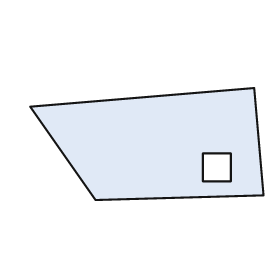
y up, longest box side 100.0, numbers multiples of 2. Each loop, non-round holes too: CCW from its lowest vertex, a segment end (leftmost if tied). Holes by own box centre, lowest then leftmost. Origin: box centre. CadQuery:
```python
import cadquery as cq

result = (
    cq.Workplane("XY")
    .moveTo(-22.0, -24.0)
    .lineTo(50.0, -22.0)
    .lineTo(46.0, 24.0)
    .lineTo(-50.0, 16.0)
    .close()
    .moveTo(24.0, -16.0)
    .lineTo(36.0, -16.0)
    .lineTo(36.0, -4.0)
    .lineTo(24.0, -4.0)
    .close()
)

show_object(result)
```